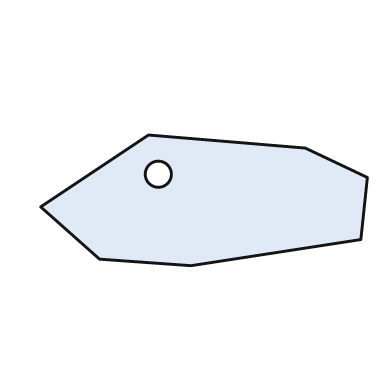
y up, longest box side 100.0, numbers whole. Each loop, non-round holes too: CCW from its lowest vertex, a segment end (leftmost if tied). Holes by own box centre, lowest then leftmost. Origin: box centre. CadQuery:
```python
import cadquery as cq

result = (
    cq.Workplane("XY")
    .moveTo(-4.0, -20.0)
    .lineTo(48.0, -12.0)
    .lineTo(50.0, 7.0)
    .lineTo(31.0, 16.0)
    .lineTo(-17.0, 20.0)
    .lineTo(-50.0, -2.0)
    .lineTo(-32.0, -18.0)
    .close()
    .moveTo(-14.0, 8.0)
    .circle(4.0)
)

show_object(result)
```